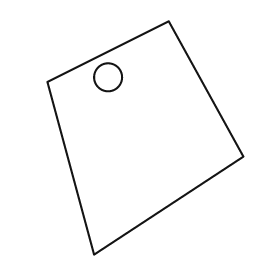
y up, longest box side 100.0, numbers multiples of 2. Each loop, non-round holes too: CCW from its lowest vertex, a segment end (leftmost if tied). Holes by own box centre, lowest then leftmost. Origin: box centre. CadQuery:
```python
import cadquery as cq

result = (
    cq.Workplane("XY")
    .moveTo(-22.0, -50.0)
    .lineTo(42.0, -8.0)
    .lineTo(10.0, 50.0)
    .lineTo(-42.0, 24.0)
    .close()
    .moveTo(-16.0, 26.0)
    .circle(6.0)
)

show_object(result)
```